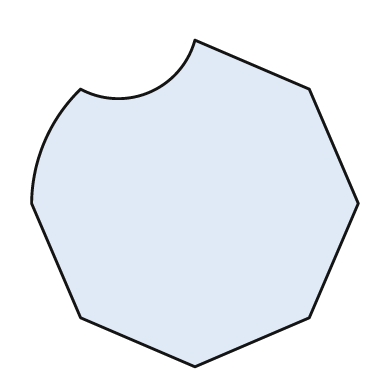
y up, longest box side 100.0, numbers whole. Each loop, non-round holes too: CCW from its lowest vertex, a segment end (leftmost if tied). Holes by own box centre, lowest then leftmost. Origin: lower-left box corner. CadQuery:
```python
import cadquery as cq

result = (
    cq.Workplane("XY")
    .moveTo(50.0, 0.0)
    .lineTo(85.0, 15.0)
    .lineTo(100.0, 50.0)
    .lineTo(85.0, 85.0)
    .lineTo(50.0, 100.0)
    .threePointArc((36.0, 84.0), (15.0, 85.0))
    .threePointArc((4.0, 69.0), (0.0, 50.0))
    .lineTo(15.0, 15.0)
    .close()
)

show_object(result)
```